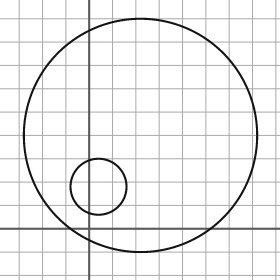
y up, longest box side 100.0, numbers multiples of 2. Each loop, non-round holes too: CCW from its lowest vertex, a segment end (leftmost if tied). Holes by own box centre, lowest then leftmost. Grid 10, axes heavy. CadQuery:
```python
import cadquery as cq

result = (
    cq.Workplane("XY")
    .moveTo(22.0, 40.0)
    .circle(50.0)
    .moveTo(4.0, 18.0)
    .circle(12.0)
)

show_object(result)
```